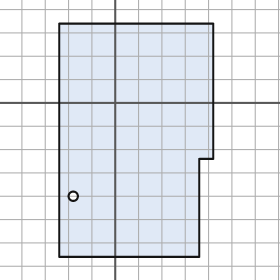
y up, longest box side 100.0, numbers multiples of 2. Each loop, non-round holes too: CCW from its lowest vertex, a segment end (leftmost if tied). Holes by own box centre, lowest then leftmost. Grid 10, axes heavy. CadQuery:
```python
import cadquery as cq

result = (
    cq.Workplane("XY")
    .moveTo(-24.0, -66.0)
    .lineTo(36.0, -66.0)
    .lineTo(36.0, -24.0)
    .lineTo(42.0, -24.0)
    .lineTo(42.0, 34.0)
    .lineTo(-24.0, 34.0)
    .close()
    .moveTo(-18.0, -40.0)
    .circle(2.0)
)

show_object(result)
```